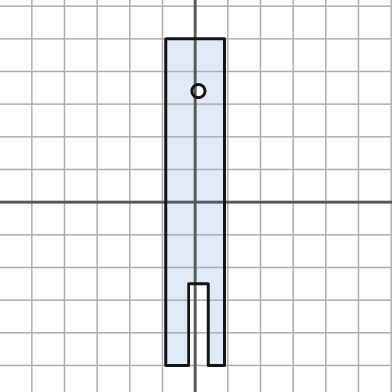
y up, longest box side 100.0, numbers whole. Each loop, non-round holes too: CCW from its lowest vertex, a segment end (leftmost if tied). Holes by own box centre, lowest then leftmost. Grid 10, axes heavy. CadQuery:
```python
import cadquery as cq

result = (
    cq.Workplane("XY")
    .moveTo(-9.0, -50.0)
    .lineTo(-2.0, -50.0)
    .lineTo(-2.0, -25.0)
    .lineTo(4.0, -25.0)
    .lineTo(4.0, -50.0)
    .lineTo(9.0, -50.0)
    .lineTo(9.0, 50.0)
    .lineTo(-9.0, 50.0)
    .close()
    .moveTo(1.0, 34.0)
    .circle(2.0)
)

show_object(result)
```